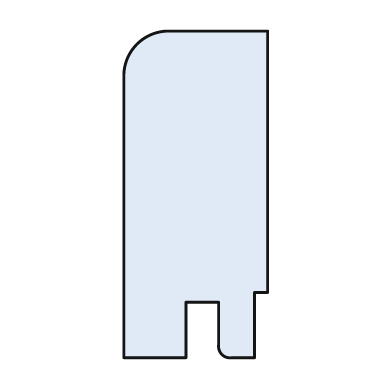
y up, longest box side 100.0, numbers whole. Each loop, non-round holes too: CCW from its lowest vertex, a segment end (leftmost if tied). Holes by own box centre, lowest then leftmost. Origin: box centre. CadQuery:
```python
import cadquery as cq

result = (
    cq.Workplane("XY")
    .moveTo(-22.0, -50.0)
    .lineTo(-3.0, -50.0)
    .lineTo(-3.0, -33.0)
    .lineTo(7.0, -33.0)
    .lineTo(7.0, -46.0)
    .threePointArc((8.0, -49.0), (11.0, -50.0))
    .lineTo(18.0, -50.0)
    .lineTo(18.0, -30.0)
    .lineTo(22.0, -30.0)
    .lineTo(22.0, 50.0)
    .lineTo(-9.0, 50.0)
    .threePointArc((-18.0, 46.0), (-22.0, 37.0))
    .close()
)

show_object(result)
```